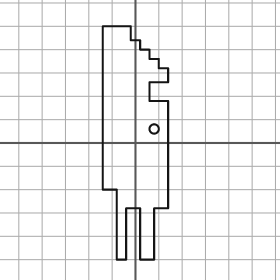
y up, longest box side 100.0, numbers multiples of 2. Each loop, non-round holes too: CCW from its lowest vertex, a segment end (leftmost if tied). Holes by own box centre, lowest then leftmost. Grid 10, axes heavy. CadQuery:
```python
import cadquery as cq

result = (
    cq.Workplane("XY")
    .moveTo(-8.0, -50.0)
    .lineTo(-4.0, -50.0)
    .lineTo(-4.0, -28.0)
    .lineTo(2.0, -28.0)
    .lineTo(2.0, -50.0)
    .lineTo(8.0, -50.0)
    .lineTo(8.0, -28.0)
    .lineTo(14.0, -28.0)
    .lineTo(14.0, 18.0)
    .lineTo(6.0, 18.0)
    .lineTo(6.0, 26.0)
    .lineTo(14.0, 26.0)
    .lineTo(14.0, 32.0)
    .lineTo(10.0, 32.0)
    .lineTo(10.0, 36.0)
    .lineTo(6.0, 36.0)
    .lineTo(6.0, 40.0)
    .lineTo(2.0, 40.0)
    .lineTo(2.0, 44.0)
    .lineTo(-2.0, 44.0)
    .lineTo(-2.0, 50.0)
    .lineTo(-14.0, 50.0)
    .lineTo(-14.0, -20.0)
    .lineTo(-8.0, -20.0)
    .close()
    .moveTo(8.0, 6.0)
    .circle(2.0)
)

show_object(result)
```